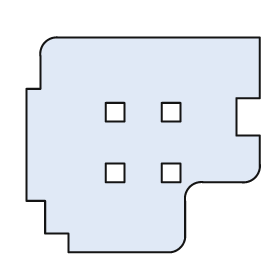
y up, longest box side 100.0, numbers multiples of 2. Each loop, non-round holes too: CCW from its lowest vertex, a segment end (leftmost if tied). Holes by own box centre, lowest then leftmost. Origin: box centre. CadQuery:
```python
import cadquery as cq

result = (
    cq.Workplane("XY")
    .moveTo(-32.0, -46.0)
    .lineTo(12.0, -46.0)
    .threePointArc((16.0, -44.0), (18.0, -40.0))
    .lineTo(18.0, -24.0)
    .threePointArc((20.0, -18.0), (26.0, -16.0))
    .lineTo(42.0, -16.0)
    .threePointArc((48.0, -14.0), (50.0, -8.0))
    .lineTo(50.0, 4.0)
    .lineTo(40.0, 4.0)
    .lineTo(40.0, 20.0)
    .lineTo(50.0, 20.0)
    .lineTo(50.0, 46.0)
    .lineTo(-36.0, 46.0)
    .threePointArc((-42.0, 44.0), (-44.0, 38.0))
    .lineTo(-44.0, 24.0)
    .lineTo(-50.0, 24.0)
    .lineTo(-50.0, -24.0)
    .lineTo(-42.0, -24.0)
    .lineTo(-42.0, -38.0)
    .lineTo(-32.0, -38.0)
    .close()
    .moveTo(-16.0, -16.0)
    .lineTo(-8.0, -16.0)
    .lineTo(-8.0, -8.0)
    .lineTo(-16.0, -8.0)
    .close()
    .moveTo(8.0, -16.0)
    .lineTo(16.0, -16.0)
    .lineTo(16.0, -8.0)
    .lineTo(8.0, -8.0)
    .close()
    .moveTo(-16.0, 10.0)
    .lineTo(-8.0, 10.0)
    .lineTo(-8.0, 18.0)
    .lineTo(-16.0, 18.0)
    .close()
    .moveTo(8.0, 10.0)
    .lineTo(16.0, 10.0)
    .lineTo(16.0, 18.0)
    .lineTo(8.0, 18.0)
    .close()
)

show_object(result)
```